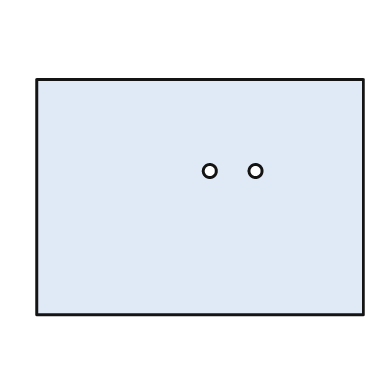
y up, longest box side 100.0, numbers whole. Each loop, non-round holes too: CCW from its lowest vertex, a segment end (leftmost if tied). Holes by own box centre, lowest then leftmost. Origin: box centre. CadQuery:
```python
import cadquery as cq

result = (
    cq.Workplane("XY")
    .moveTo(-50.0, -36.0)
    .lineTo(50.0, -36.0)
    .lineTo(50.0, 36.0)
    .lineTo(-50.0, 36.0)
    .close()
    .moveTo(3.0, 8.0)
    .circle(2.0)
    .moveTo(17.0, 8.0)
    .circle(2.0)
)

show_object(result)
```